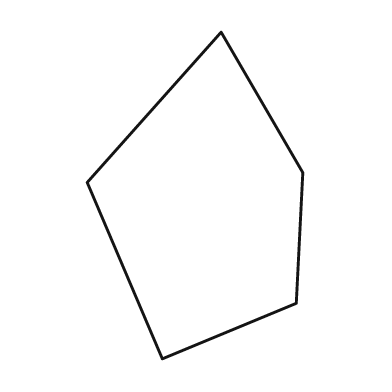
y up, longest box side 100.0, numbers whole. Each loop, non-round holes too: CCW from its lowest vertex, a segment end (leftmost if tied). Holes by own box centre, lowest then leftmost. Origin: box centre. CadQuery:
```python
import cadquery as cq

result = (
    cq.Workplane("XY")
    .moveTo(-10.0, -50.0)
    .lineTo(31.0, -33.0)
    .lineTo(33.0, 7.0)
    .lineTo(8.0, 50.0)
    .lineTo(-33.0, 4.0)
    .close()
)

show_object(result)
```